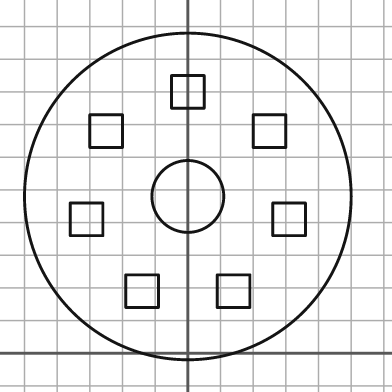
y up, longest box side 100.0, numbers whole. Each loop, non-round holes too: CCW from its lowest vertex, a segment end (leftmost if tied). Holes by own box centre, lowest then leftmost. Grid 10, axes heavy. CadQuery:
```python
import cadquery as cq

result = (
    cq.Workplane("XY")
    .moveTo(0.0, 48.0)
    .circle(50.0)
    .moveTo(-19.0, 14.0)
    .lineTo(-9.0, 14.0)
    .lineTo(-9.0, 24.0)
    .lineTo(-19.0, 24.0)
    .close()
    .moveTo(9.0, 14.0)
    .lineTo(19.0, 14.0)
    .lineTo(19.0, 24.0)
    .lineTo(9.0, 24.0)
    .close()
    .moveTo(-36.0, 36.0)
    .lineTo(-26.0, 36.0)
    .lineTo(-26.0, 46.0)
    .lineTo(-36.0, 46.0)
    .close()
    .moveTo(26.0, 36.0)
    .lineTo(36.0, 36.0)
    .lineTo(36.0, 46.0)
    .lineTo(26.0, 46.0)
    .close()
    .moveTo(0.0, 48.0)
    .circle(11.0)
    .moveTo(-30.0, 63.0)
    .lineTo(-20.0, 63.0)
    .lineTo(-20.0, 73.0)
    .lineTo(-30.0, 73.0)
    .close()
    .moveTo(20.0, 63.0)
    .lineTo(30.0, 63.0)
    .lineTo(30.0, 73.0)
    .lineTo(20.0, 73.0)
    .close()
    .moveTo(-5.0, 75.0)
    .lineTo(5.0, 75.0)
    .lineTo(5.0, 85.0)
    .lineTo(-5.0, 85.0)
    .close()
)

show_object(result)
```